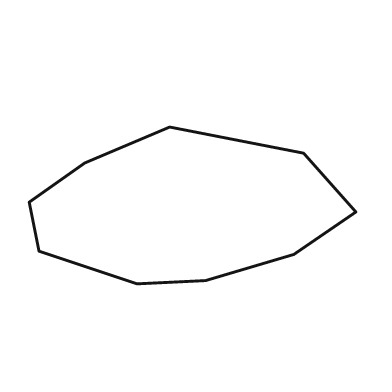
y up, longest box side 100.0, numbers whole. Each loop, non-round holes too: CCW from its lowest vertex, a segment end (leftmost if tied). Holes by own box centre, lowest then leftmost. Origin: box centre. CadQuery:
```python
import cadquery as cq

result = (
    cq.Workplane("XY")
    .moveTo(-17.0, -24.0)
    .lineTo(4.0, -23.0)
    .lineTo(31.0, -15.0)
    .lineTo(50.0, -2.0)
    .lineTo(34.0, 16.0)
    .lineTo(-7.0, 24.0)
    .lineTo(-33.0, 13.0)
    .lineTo(-50.0, 1.0)
    .lineTo(-47.0, -14.0)
    .close()
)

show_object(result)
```